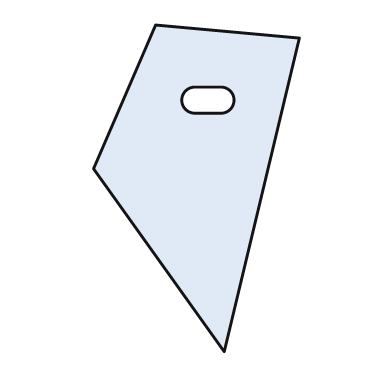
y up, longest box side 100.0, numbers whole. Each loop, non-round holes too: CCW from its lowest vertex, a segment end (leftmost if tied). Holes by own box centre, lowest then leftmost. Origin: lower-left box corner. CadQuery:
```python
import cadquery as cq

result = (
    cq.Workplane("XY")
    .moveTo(40.0, 0.0)
    .lineTo(63.0, 96.0)
    .lineTo(19.0, 100.0)
    .lineTo(0.0, 56.0)
    .close()
    .moveTo(31.0, 73.0)
    .lineTo(39.0, 73.0)
    .threePointArc((43.0, 77.0), (39.0, 81.0))
    .lineTo(31.0, 81.0)
    .threePointArc((27.0, 77.0), (31.0, 73.0))
    .close()
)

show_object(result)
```